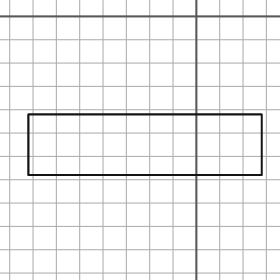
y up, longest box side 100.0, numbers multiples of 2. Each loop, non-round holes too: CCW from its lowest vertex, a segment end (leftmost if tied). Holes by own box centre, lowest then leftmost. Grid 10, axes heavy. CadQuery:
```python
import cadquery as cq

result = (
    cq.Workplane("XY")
    .moveTo(-72.0, -68.0)
    .lineTo(28.0, -68.0)
    .lineTo(28.0, -42.0)
    .lineTo(-72.0, -42.0)
    .close()
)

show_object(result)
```